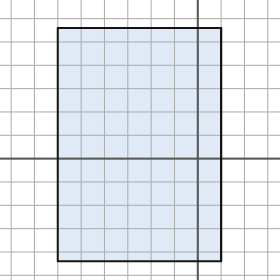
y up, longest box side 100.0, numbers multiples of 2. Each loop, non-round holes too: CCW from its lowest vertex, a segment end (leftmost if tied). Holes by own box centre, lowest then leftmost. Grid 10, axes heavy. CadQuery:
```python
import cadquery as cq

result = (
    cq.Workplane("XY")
    .moveTo(-60.0, -44.0)
    .lineTo(10.0, -44.0)
    .lineTo(10.0, 56.0)
    .lineTo(-60.0, 56.0)
    .close()
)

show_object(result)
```